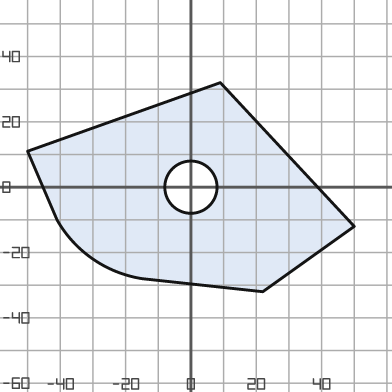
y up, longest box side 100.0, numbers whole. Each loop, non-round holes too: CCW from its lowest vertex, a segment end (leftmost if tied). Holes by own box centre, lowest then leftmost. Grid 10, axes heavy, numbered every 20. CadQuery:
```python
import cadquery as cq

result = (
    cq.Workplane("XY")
    .moveTo(22.0, -32.0)
    .lineTo(50.0, -12.0)
    .lineTo(9.0, 32.0)
    .lineTo(-50.0, 11.0)
    .lineTo(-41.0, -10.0)
    .threePointArc((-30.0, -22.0), (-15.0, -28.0))
    .close()
    .moveTo(0.0, 0.0)
    .circle(8.0)
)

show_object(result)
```